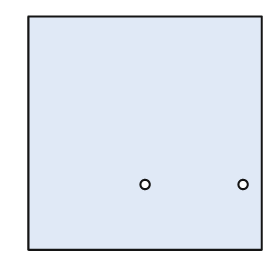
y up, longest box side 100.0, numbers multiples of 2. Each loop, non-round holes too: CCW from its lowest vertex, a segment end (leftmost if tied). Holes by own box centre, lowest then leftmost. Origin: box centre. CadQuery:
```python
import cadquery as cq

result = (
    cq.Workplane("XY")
    .moveTo(-50.0, -50.0)
    .lineTo(50.0, -50.0)
    .lineTo(50.0, 50.0)
    .lineTo(-50.0, 50.0)
    .close()
    .moveTo(0.0, -22.0)
    .circle(2.0)
    .moveTo(42.0, -22.0)
    .circle(2.0)
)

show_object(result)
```